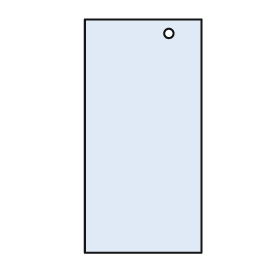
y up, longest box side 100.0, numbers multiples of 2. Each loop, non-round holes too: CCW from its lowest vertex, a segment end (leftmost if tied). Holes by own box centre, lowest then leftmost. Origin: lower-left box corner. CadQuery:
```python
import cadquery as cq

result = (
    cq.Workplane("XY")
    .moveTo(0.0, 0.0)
    .lineTo(50.0, 0.0)
    .lineTo(50.0, 100.0)
    .lineTo(0.0, 100.0)
    .close()
    .moveTo(36.0, 94.0)
    .circle(2.0)
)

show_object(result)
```